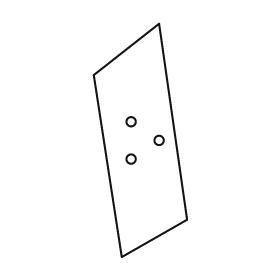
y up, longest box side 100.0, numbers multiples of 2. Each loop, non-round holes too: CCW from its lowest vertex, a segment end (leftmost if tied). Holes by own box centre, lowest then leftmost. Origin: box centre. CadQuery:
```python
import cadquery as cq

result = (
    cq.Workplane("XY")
    .moveTo(-8.0, -50.0)
    .lineTo(20.0, -34.0)
    .lineTo(8.0, 50.0)
    .lineTo(-20.0, 28.0)
    .close()
    .moveTo(-4.0, -8.0)
    .circle(2.0)
    .moveTo(8.0, 0.0)
    .circle(2.0)
    .moveTo(-4.0, 8.0)
    .circle(2.0)
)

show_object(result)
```